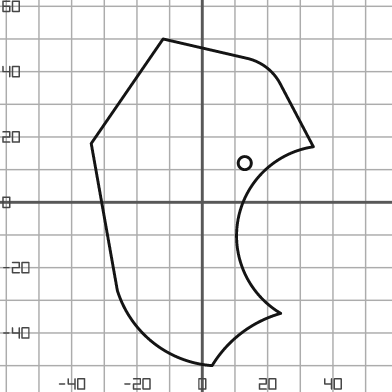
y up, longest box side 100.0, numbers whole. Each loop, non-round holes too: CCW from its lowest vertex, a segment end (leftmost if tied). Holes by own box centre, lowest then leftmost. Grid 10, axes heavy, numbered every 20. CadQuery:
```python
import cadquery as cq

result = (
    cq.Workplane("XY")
    .moveTo(3.0, -50.0)
    .threePointArc((12.0, -40.0), (24.0, -34.0))
    .threePointArc((11.0, -5.0), (34.0, 17.0))
    .lineTo(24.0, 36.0)
    .threePointArc((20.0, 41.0), (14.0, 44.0))
    .lineTo(-12.0, 50.0)
    .lineTo(-34.0, 18.0)
    .lineTo(-26.0, -27.0)
    .threePointArc((-15.0, -43.0), (3.0, -50.0))
    .close()
    .moveTo(13.0, 12.0)
    .circle(2.0)
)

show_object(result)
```